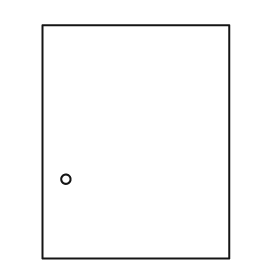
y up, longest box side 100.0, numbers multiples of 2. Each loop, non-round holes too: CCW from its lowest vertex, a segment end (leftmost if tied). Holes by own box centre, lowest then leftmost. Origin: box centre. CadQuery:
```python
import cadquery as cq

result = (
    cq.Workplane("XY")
    .moveTo(-40.0, -50.0)
    .lineTo(40.0, -50.0)
    .lineTo(40.0, 50.0)
    .lineTo(-40.0, 50.0)
    .close()
    .moveTo(-30.0, -16.0)
    .circle(2.0)
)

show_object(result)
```